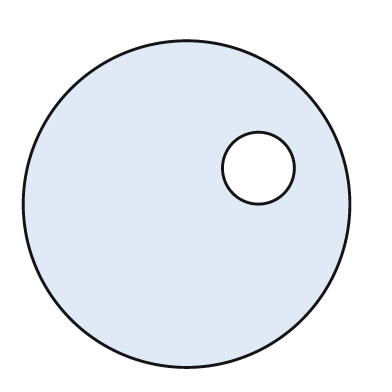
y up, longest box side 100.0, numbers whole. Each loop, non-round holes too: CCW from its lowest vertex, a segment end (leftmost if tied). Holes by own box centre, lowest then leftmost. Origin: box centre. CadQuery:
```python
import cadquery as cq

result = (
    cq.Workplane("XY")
    .moveTo(0.0, 0.0)
    .circle(50.0)
    .moveTo(22.0, 11.0)
    .circle(11.0)
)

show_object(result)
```